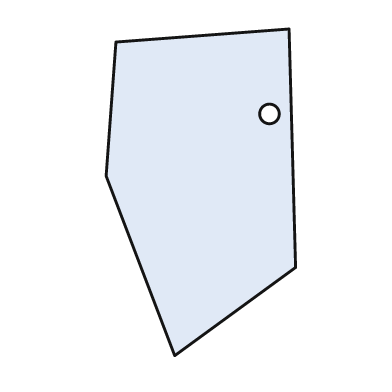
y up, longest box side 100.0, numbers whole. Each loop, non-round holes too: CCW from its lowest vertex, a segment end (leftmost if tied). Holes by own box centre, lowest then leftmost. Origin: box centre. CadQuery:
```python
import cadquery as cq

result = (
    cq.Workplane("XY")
    .moveTo(-8.0, -50.0)
    .lineTo(29.0, -23.0)
    .lineTo(27.0, 50.0)
    .lineTo(-26.0, 46.0)
    .lineTo(-29.0, 5.0)
    .close()
    .moveTo(21.0, 24.0)
    .circle(3.0)
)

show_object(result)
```